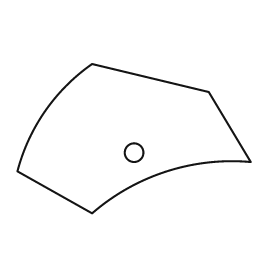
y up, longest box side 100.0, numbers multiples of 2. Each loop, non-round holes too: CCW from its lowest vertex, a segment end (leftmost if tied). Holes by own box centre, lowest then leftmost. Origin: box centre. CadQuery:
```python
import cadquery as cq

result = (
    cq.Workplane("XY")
    .moveTo(-18.0, -32.0)
    .threePointArc((14.0, -14.0), (50.0, -10.0))
    .lineTo(32.0, 20.0)
    .lineTo(-18.0, 32.0)
    .threePointArc((-38.0, 12.0), (-50.0, -14.0))
    .close()
    .moveTo(0.0, -6.0)
    .circle(4.0)
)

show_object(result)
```